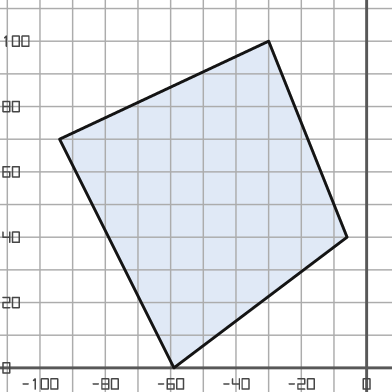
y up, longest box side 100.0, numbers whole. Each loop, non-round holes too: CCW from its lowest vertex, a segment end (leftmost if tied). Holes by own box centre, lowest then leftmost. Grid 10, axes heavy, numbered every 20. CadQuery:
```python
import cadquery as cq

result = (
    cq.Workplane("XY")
    .moveTo(-59.0, 0.0)
    .lineTo(-6.0, 40.0)
    .lineTo(-30.0, 100.0)
    .lineTo(-94.0, 70.0)
    .close()
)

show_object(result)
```